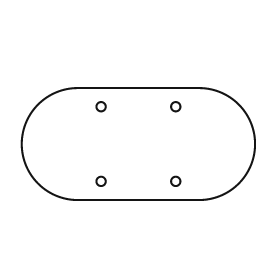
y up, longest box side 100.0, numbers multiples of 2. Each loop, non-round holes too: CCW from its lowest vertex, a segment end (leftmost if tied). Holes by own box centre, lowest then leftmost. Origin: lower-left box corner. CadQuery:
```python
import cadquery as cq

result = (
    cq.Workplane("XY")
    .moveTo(24.0, 0.0)
    .lineTo(76.0, 0.0)
    .threePointArc((100.0, 24.0), (76.0, 48.0))
    .lineTo(24.0, 48.0)
    .threePointArc((0.0, 24.0), (24.0, 0.0))
    .close()
    .moveTo(34.0, 8.0)
    .circle(2.0)
    .moveTo(66.0, 8.0)
    .circle(2.0)
    .moveTo(34.0, 40.0)
    .circle(2.0)
    .moveTo(66.0, 40.0)
    .circle(2.0)
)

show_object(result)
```